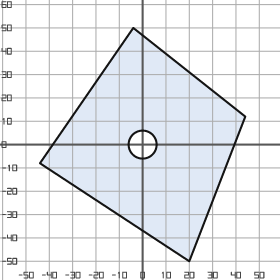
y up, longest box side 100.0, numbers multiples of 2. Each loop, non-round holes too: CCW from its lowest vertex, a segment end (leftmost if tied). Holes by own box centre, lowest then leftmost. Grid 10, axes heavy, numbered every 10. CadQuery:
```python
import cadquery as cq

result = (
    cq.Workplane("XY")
    .moveTo(20.0, -50.0)
    .lineTo(44.0, 12.0)
    .lineTo(-4.0, 50.0)
    .lineTo(-44.0, -8.0)
    .close()
    .moveTo(0.0, 0.0)
    .circle(6.0)
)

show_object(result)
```